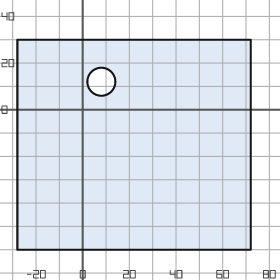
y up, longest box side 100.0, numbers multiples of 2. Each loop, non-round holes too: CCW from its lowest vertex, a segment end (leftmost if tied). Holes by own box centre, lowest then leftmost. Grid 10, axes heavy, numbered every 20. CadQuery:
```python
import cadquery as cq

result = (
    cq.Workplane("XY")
    .moveTo(-28.0, -60.0)
    .lineTo(72.0, -60.0)
    .lineTo(72.0, 30.0)
    .lineTo(-28.0, 30.0)
    .close()
    .moveTo(8.0, 12.0)
    .circle(6.0)
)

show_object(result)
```